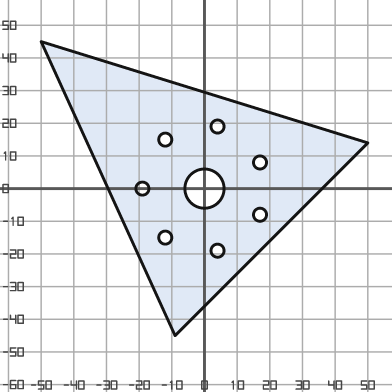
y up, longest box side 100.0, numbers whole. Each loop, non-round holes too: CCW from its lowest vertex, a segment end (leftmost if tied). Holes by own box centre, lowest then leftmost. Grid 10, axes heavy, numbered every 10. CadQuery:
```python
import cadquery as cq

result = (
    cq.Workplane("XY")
    .moveTo(-9.0, -45.0)
    .lineTo(50.0, 14.0)
    .lineTo(-50.0, 45.0)
    .close()
    .moveTo(4.0, -19.0)
    .circle(2.0)
    .moveTo(-12.0, -15.0)
    .circle(2.0)
    .moveTo(17.0, -8.0)
    .circle(2.0)
    .moveTo(-19.0, 0.0)
    .circle(2.0)
    .moveTo(0.0, 0.0)
    .circle(6.0)
    .moveTo(17.0, 8.0)
    .circle(2.0)
    .moveTo(-12.0, 15.0)
    .circle(2.0)
    .moveTo(4.0, 19.0)
    .circle(2.0)
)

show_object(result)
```